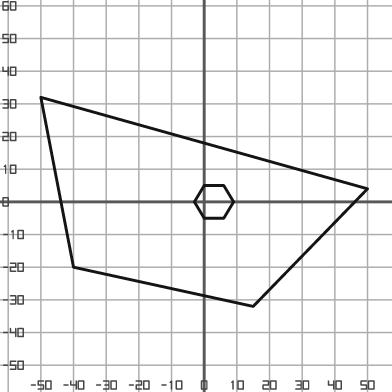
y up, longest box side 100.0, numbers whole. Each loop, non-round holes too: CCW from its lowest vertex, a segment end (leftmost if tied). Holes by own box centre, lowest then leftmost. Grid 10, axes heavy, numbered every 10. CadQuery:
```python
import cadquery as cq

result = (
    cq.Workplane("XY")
    .moveTo(15.0, -32.0)
    .lineTo(50.0, 4.0)
    .lineTo(-50.0, 32.0)
    .lineTo(-40.0, -20.0)
    .close()
    .moveTo(0.0, -5.0)
    .lineTo(6.0, -5.0)
    .lineTo(9.0, 0.0)
    .lineTo(6.0, 5.0)
    .lineTo(0.0, 5.0)
    .lineTo(-3.0, 0.0)
    .close()
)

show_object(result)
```